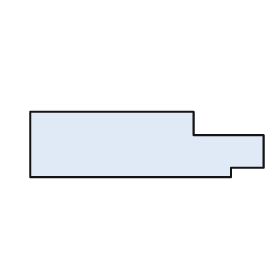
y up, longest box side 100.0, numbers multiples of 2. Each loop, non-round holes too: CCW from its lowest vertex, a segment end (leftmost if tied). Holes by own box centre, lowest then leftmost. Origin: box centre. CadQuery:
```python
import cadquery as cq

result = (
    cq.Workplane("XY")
    .moveTo(-50.0, -14.0)
    .lineTo(36.0, -14.0)
    .lineTo(36.0, -10.0)
    .lineTo(50.0, -10.0)
    .lineTo(50.0, 4.0)
    .lineTo(20.0, 4.0)
    .lineTo(20.0, 14.0)
    .lineTo(-50.0, 14.0)
    .close()
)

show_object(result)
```